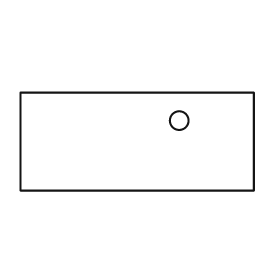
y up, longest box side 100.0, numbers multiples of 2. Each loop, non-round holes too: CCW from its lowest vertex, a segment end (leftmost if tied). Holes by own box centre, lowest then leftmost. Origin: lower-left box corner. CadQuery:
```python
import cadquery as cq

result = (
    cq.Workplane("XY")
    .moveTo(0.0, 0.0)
    .lineTo(100.0, 0.0)
    .lineTo(100.0, 42.0)
    .lineTo(0.0, 42.0)
    .close()
    .moveTo(68.0, 30.0)
    .circle(4.0)
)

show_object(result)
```